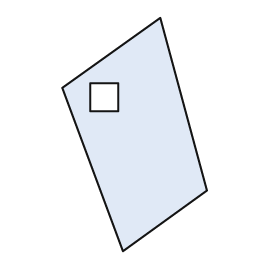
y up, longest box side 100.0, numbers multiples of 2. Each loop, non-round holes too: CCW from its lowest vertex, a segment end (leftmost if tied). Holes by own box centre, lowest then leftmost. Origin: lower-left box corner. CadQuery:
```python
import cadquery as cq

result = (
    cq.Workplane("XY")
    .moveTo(26.0, 0.0)
    .lineTo(62.0, 26.0)
    .lineTo(42.0, 100.0)
    .lineTo(0.0, 70.0)
    .close()
    .moveTo(12.0, 60.0)
    .lineTo(24.0, 60.0)
    .lineTo(24.0, 72.0)
    .lineTo(12.0, 72.0)
    .close()
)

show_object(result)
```